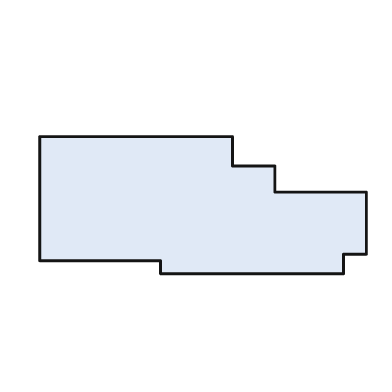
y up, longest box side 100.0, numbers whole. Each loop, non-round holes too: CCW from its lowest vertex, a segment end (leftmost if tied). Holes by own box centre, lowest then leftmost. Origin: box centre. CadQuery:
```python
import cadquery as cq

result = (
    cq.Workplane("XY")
    .moveTo(-13.0, -21.0)
    .lineTo(43.0, -21.0)
    .lineTo(43.0, -15.0)
    .lineTo(50.0, -15.0)
    .lineTo(50.0, 4.0)
    .lineTo(22.0, 4.0)
    .lineTo(22.0, 12.0)
    .lineTo(9.0, 12.0)
    .lineTo(9.0, 21.0)
    .lineTo(-50.0, 21.0)
    .lineTo(-50.0, -17.0)
    .lineTo(-13.0, -17.0)
    .close()
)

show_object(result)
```